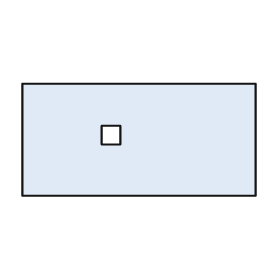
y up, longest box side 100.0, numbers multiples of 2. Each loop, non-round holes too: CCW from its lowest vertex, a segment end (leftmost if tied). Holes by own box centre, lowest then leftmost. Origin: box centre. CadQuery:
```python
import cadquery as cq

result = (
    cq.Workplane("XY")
    .moveTo(-50.0, -24.0)
    .lineTo(50.0, -24.0)
    .lineTo(50.0, 24.0)
    .lineTo(-50.0, 24.0)
    .close()
    .moveTo(-16.0, -2.0)
    .lineTo(-8.0, -2.0)
    .lineTo(-8.0, 6.0)
    .lineTo(-16.0, 6.0)
    .close()
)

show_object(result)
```